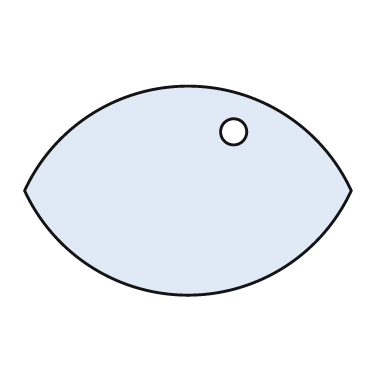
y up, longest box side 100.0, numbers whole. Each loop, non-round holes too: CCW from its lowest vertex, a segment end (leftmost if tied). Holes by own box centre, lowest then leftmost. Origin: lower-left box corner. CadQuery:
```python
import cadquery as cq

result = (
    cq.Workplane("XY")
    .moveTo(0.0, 32.0)
    .threePointArc((50.0, 0.0), (100.0, 32.0))
    .threePointArc((50.0, 64.0), (0.0, 32.0))
    .close()
    .moveTo(64.0, 50.0)
    .circle(4.0)
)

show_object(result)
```